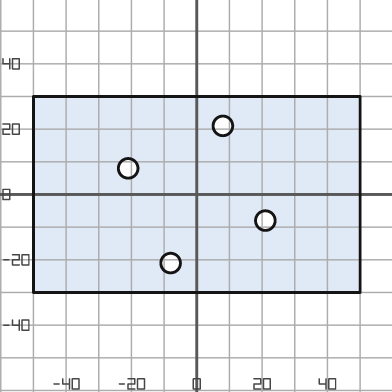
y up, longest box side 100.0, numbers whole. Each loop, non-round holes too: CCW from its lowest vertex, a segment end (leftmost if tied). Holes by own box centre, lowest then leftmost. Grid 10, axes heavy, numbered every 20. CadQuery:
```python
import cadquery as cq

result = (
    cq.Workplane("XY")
    .moveTo(-50.0, -30.0)
    .lineTo(50.0, -30.0)
    .lineTo(50.0, 30.0)
    .lineTo(-50.0, 30.0)
    .close()
    .moveTo(-8.0, -21.0)
    .circle(3.0)
    .moveTo(21.0, -8.0)
    .circle(3.0)
    .moveTo(-21.0, 8.0)
    .circle(3.0)
    .moveTo(8.0, 21.0)
    .circle(3.0)
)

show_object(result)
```